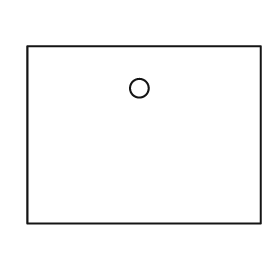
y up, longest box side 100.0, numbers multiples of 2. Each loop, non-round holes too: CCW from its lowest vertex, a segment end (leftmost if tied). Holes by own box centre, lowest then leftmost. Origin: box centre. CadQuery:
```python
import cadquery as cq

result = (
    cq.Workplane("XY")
    .moveTo(-50.0, -38.0)
    .lineTo(50.0, -38.0)
    .lineTo(50.0, 38.0)
    .lineTo(-50.0, 38.0)
    .close()
    .moveTo(-2.0, 20.0)
    .circle(4.0)
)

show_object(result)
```